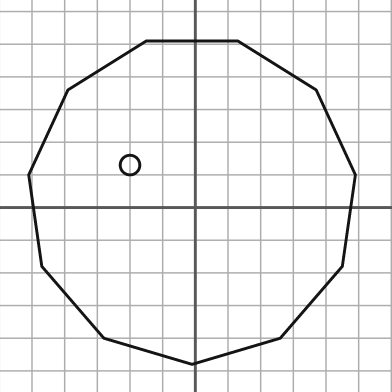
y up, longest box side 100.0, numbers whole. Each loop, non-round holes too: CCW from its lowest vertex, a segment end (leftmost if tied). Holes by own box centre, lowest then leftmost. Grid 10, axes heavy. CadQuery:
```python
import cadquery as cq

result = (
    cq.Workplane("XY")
    .moveTo(-1.0, -48.0)
    .lineTo(26.0, -40.0)
    .lineTo(45.0, -18.0)
    .lineTo(49.0, 10.0)
    .lineTo(37.0, 36.0)
    .lineTo(13.0, 51.0)
    .lineTo(-15.0, 51.0)
    .lineTo(-39.0, 36.0)
    .lineTo(-51.0, 10.0)
    .lineTo(-47.0, -18.0)
    .lineTo(-28.0, -40.0)
    .close()
    .moveTo(-20.0, 13.0)
    .circle(3.0)
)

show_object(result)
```